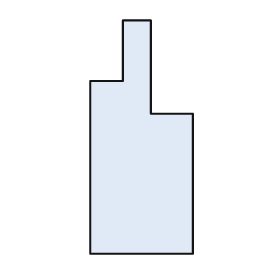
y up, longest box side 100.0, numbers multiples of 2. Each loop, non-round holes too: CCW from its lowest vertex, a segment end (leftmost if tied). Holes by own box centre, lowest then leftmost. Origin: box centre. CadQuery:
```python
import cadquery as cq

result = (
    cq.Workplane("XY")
    .moveTo(-22.0, -50.0)
    .lineTo(22.0, -50.0)
    .lineTo(22.0, 10.0)
    .lineTo(4.0, 10.0)
    .lineTo(4.0, 50.0)
    .lineTo(-8.0, 50.0)
    .lineTo(-8.0, 24.0)
    .lineTo(-22.0, 24.0)
    .close()
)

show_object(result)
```